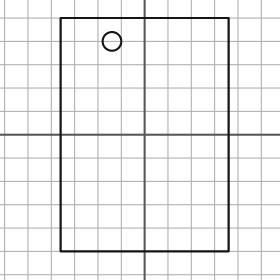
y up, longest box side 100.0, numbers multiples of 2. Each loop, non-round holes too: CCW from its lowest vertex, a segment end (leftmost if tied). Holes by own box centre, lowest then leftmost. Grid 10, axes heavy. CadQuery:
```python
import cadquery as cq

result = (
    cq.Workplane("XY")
    .moveTo(-36.0, -50.0)
    .lineTo(36.0, -50.0)
    .lineTo(36.0, 50.0)
    .lineTo(-36.0, 50.0)
    .close()
    .moveTo(-14.0, 40.0)
    .circle(4.0)
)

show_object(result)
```